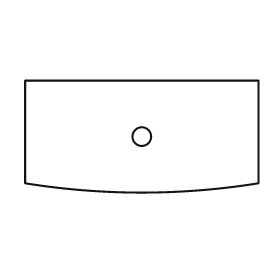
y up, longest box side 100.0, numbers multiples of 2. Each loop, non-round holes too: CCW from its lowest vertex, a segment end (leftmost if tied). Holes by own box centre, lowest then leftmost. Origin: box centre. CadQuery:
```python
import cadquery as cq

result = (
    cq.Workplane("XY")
    .moveTo(-50.0, -20.0)
    .threePointArc((0.0, -24.0), (50.0, -20.0))
    .lineTo(50.0, 24.0)
    .lineTo(-50.0, 24.0)
    .close()
    .moveTo(0.0, 0.0)
    .circle(4.0)
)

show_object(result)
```